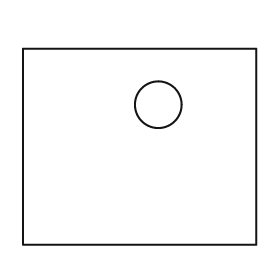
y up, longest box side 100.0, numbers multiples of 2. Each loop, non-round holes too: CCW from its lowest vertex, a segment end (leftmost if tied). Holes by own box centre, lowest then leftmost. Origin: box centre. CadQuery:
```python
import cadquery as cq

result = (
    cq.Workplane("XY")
    .moveTo(-50.0, -42.0)
    .lineTo(50.0, -42.0)
    .lineTo(50.0, 42.0)
    .lineTo(-50.0, 42.0)
    .close()
    .moveTo(8.0, 18.0)
    .circle(10.0)
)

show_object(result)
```